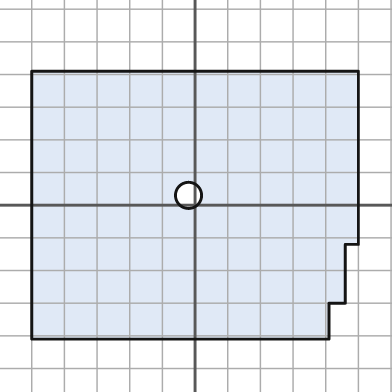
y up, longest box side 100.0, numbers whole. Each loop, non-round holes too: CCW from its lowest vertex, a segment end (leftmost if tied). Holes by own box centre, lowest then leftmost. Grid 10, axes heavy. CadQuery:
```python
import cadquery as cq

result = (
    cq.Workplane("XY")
    .moveTo(-50.0, -41.0)
    .lineTo(41.0, -41.0)
    .lineTo(41.0, -30.0)
    .lineTo(46.0, -30.0)
    .lineTo(46.0, -12.0)
    .lineTo(50.0, -12.0)
    .lineTo(50.0, 41.0)
    .lineTo(-50.0, 41.0)
    .close()
    .moveTo(-2.0, 3.0)
    .circle(4.0)
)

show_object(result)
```